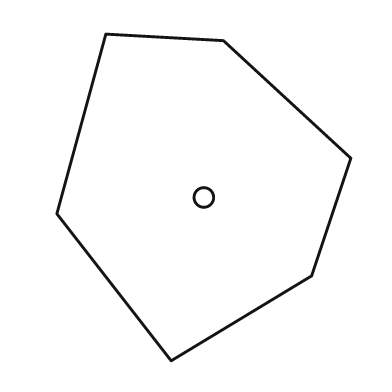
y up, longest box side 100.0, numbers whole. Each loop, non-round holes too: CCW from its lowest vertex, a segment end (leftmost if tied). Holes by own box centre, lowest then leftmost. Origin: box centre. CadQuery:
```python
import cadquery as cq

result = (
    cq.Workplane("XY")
    .moveTo(-10.0, -50.0)
    .lineTo(33.0, -24.0)
    .lineTo(45.0, 12.0)
    .lineTo(6.0, 48.0)
    .lineTo(-30.0, 50.0)
    .lineTo(-45.0, -5.0)
    .close()
    .moveTo(0.0, 0.0)
    .circle(3.0)
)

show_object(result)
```